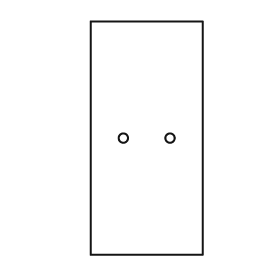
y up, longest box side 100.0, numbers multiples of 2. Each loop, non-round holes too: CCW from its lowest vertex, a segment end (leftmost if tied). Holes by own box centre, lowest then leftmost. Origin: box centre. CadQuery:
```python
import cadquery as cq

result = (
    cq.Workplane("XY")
    .moveTo(-24.0, -50.0)
    .lineTo(24.0, -50.0)
    .lineTo(24.0, 50.0)
    .lineTo(-24.0, 50.0)
    .close()
    .moveTo(-10.0, 0.0)
    .circle(2.0)
    .moveTo(10.0, 0.0)
    .circle(2.0)
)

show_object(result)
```